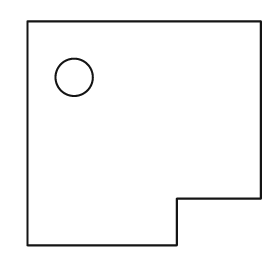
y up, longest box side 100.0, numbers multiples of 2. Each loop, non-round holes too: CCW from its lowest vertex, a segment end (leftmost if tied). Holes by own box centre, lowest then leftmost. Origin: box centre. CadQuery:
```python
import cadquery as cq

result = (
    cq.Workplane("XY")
    .moveTo(-50.0, -48.0)
    .lineTo(14.0, -48.0)
    .lineTo(14.0, -28.0)
    .lineTo(50.0, -28.0)
    .lineTo(50.0, 48.0)
    .lineTo(-50.0, 48.0)
    .close()
    .moveTo(-30.0, 24.0)
    .circle(8.0)
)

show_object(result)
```